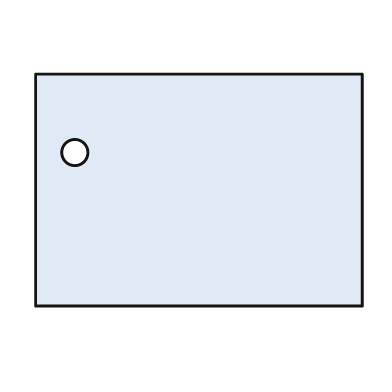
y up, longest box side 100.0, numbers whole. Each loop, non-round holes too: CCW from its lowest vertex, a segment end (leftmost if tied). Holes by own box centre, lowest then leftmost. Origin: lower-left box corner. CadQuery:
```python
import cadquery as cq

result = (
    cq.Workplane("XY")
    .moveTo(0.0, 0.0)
    .lineTo(100.0, 0.0)
    .lineTo(100.0, 71.0)
    .lineTo(0.0, 71.0)
    .close()
    .moveTo(12.0, 47.0)
    .circle(4.0)
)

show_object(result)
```